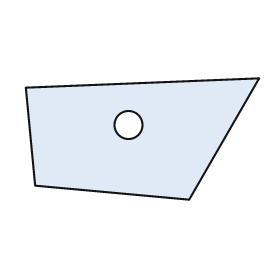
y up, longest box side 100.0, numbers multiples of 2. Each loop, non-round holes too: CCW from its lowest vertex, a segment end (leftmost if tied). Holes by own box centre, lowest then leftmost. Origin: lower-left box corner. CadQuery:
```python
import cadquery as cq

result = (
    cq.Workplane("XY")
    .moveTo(70.0, 0.0)
    .lineTo(100.0, 52.0)
    .lineTo(0.0, 48.0)
    .lineTo(4.0, 6.0)
    .close()
    .moveTo(44.0, 32.0)
    .circle(6.0)
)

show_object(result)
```